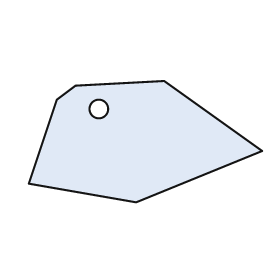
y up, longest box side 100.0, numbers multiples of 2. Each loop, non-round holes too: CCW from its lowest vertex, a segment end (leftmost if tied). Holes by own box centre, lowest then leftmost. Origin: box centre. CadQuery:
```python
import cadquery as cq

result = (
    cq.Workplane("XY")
    .moveTo(-4.0, -26.0)
    .lineTo(50.0, -4.0)
    .lineTo(8.0, 26.0)
    .lineTo(-30.0, 24.0)
    .lineTo(-38.0, 18.0)
    .lineTo(-50.0, -18.0)
    .close()
    .moveTo(-20.0, 14.0)
    .circle(4.0)
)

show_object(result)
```